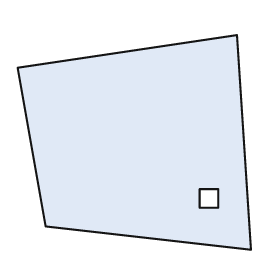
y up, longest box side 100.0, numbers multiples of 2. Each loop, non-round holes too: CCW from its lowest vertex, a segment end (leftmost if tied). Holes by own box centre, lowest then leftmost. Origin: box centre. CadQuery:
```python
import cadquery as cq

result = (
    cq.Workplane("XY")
    .moveTo(50.0, -46.0)
    .lineTo(44.0, 46.0)
    .lineTo(-50.0, 32.0)
    .lineTo(-38.0, -36.0)
    .close()
    .moveTo(28.0, -28.0)
    .lineTo(36.0, -28.0)
    .lineTo(36.0, -20.0)
    .lineTo(28.0, -20.0)
    .close()
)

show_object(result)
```